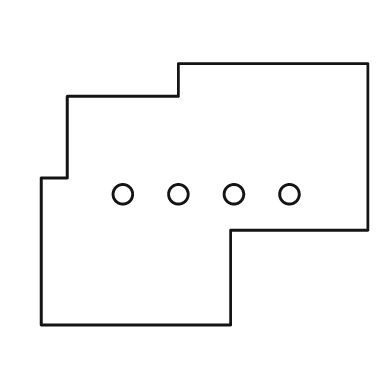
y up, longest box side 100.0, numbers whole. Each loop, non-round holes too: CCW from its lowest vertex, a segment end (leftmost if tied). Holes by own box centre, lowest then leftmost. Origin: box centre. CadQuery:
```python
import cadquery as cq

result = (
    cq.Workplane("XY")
    .moveTo(-50.0, -40.0)
    .lineTo(8.0, -40.0)
    .lineTo(8.0, -11.0)
    .lineTo(50.0, -11.0)
    .lineTo(50.0, 40.0)
    .lineTo(-8.0, 40.0)
    .lineTo(-8.0, 30.0)
    .lineTo(-42.0, 30.0)
    .lineTo(-42.0, 5.0)
    .lineTo(-50.0, 5.0)
    .close()
    .moveTo(-25.0, 0.0)
    .circle(3.0)
    .moveTo(-8.0, 0.0)
    .circle(3.0)
    .moveTo(9.0, 0.0)
    .circle(3.0)
    .moveTo(26.0, 0.0)
    .circle(3.0)
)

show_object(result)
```